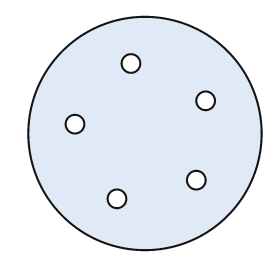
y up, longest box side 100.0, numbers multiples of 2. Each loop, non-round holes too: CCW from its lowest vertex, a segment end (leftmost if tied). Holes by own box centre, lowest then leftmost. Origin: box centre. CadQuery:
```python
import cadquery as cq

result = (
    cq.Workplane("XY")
    .moveTo(0.0, 0.0)
    .circle(50.0)
    .moveTo(-12.0, -28.0)
    .circle(4.0)
    .moveTo(22.0, -20.0)
    .circle(4.0)
    .moveTo(-30.0, 4.0)
    .circle(4.0)
    .moveTo(26.0, 14.0)
    .circle(4.0)
    .moveTo(-6.0, 30.0)
    .circle(4.0)
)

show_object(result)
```